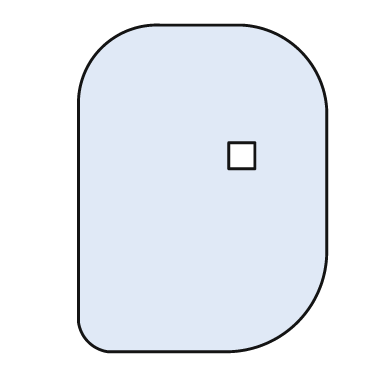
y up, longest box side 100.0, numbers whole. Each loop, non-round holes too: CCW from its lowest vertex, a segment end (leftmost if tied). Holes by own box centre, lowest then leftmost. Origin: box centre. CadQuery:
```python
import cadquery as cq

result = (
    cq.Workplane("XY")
    .moveTo(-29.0, -50.0)
    .lineTo(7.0, -50.0)
    .threePointArc((29.0, -41.0), (38.0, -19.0))
    .lineTo(38.0, 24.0)
    .threePointArc((30.0, 42.0), (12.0, 50.0))
    .lineTo(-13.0, 50.0)
    .threePointArc((-31.0, 43.0), (-38.0, 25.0))
    .lineTo(-38.0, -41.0)
    .threePointArc((-35.0, -47.0), (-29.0, -50.0))
    .close()
    .moveTo(8.0, 6.0)
    .lineTo(16.0, 6.0)
    .lineTo(16.0, 14.0)
    .lineTo(8.0, 14.0)
    .close()
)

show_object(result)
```